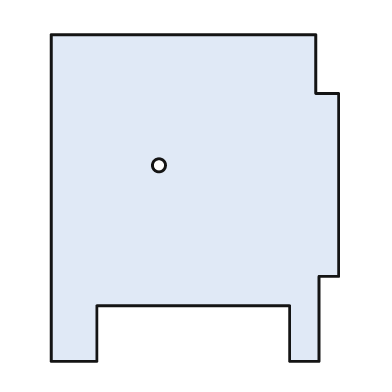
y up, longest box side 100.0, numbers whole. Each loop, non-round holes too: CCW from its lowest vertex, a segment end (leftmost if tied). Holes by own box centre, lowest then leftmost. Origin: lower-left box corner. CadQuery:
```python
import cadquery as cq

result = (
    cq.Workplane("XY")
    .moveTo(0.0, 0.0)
    .lineTo(14.0, 0.0)
    .lineTo(14.0, 17.0)
    .lineTo(73.0, 17.0)
    .lineTo(73.0, 0.0)
    .lineTo(82.0, 0.0)
    .lineTo(82.0, 26.0)
    .lineTo(88.0, 26.0)
    .lineTo(88.0, 82.0)
    .lineTo(81.0, 82.0)
    .lineTo(81.0, 100.0)
    .lineTo(0.0, 100.0)
    .close()
    .moveTo(33.0, 60.0)
    .circle(2.0)
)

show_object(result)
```